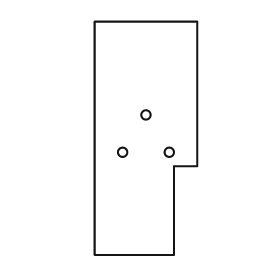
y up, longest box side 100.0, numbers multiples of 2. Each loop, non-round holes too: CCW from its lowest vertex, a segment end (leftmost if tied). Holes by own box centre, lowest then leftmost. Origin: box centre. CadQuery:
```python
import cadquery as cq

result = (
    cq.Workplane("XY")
    .moveTo(-22.0, -50.0)
    .lineTo(12.0, -50.0)
    .lineTo(12.0, -12.0)
    .lineTo(22.0, -12.0)
    .lineTo(22.0, 50.0)
    .lineTo(-22.0, 50.0)
    .close()
    .moveTo(-10.0, -6.0)
    .circle(2.0)
    .moveTo(10.0, -6.0)
    .circle(2.0)
    .moveTo(0.0, 10.0)
    .circle(2.0)
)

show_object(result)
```